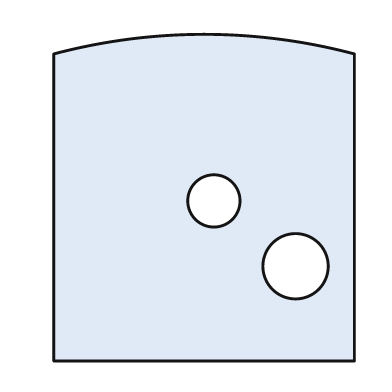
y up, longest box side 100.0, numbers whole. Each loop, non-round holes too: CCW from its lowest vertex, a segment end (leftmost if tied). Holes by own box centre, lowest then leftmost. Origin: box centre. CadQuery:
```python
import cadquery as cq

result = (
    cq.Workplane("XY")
    .moveTo(-46.0, -50.0)
    .lineTo(46.0, -50.0)
    .lineTo(46.0, 44.0)
    .threePointArc((0.0, 50.0), (-46.0, 44.0))
    .close()
    .moveTo(28.0, -21.0)
    .circle(10.0)
    .moveTo(3.0, -1.0)
    .circle(8.0)
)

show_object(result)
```